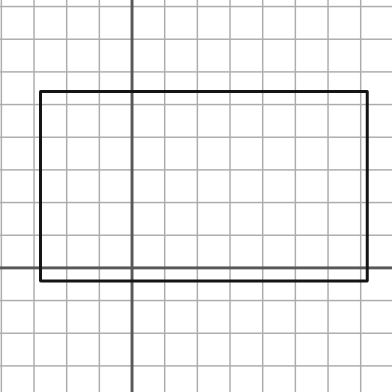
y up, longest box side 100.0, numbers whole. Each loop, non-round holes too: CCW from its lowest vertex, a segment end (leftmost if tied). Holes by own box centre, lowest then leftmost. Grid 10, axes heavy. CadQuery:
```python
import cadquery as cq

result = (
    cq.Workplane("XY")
    .moveTo(-28.0, -4.0)
    .lineTo(72.0, -4.0)
    .lineTo(72.0, 54.0)
    .lineTo(-28.0, 54.0)
    .close()
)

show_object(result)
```